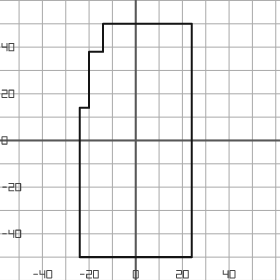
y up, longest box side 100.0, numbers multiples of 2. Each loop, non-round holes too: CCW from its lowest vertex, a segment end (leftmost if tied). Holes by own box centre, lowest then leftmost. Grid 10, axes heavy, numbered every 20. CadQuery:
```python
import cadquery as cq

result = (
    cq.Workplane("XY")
    .moveTo(-24.0, -50.0)
    .lineTo(24.0, -50.0)
    .lineTo(24.0, 50.0)
    .lineTo(-14.0, 50.0)
    .lineTo(-14.0, 38.0)
    .lineTo(-20.0, 38.0)
    .lineTo(-20.0, 14.0)
    .lineTo(-24.0, 14.0)
    .close()
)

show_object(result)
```